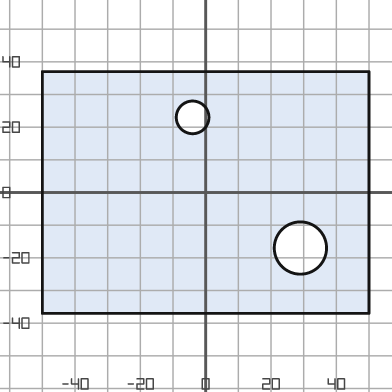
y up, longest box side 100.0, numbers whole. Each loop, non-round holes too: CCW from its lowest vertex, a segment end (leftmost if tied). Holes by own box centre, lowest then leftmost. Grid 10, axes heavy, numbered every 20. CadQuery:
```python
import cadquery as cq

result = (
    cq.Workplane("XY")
    .moveTo(-50.0, -37.0)
    .lineTo(50.0, -37.0)
    .lineTo(50.0, 37.0)
    .lineTo(-50.0, 37.0)
    .close()
    .moveTo(29.0, -17.0)
    .circle(8.0)
    .moveTo(-4.0, 23.0)
    .circle(5.0)
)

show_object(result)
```